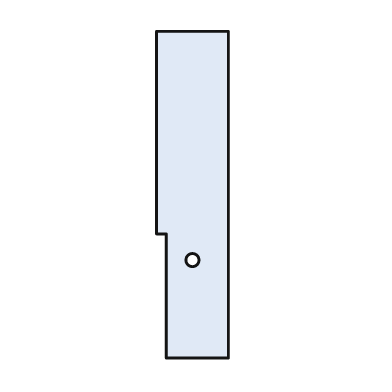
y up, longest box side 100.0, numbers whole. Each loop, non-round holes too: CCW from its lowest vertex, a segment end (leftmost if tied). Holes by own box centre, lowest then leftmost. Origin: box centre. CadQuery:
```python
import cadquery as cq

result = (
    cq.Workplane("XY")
    .moveTo(-8.0, -50.0)
    .lineTo(11.0, -50.0)
    .lineTo(11.0, 50.0)
    .lineTo(-11.0, 50.0)
    .lineTo(-11.0, -12.0)
    .lineTo(-8.0, -12.0)
    .close()
    .moveTo(0.0, -20.0)
    .circle(2.0)
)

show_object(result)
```